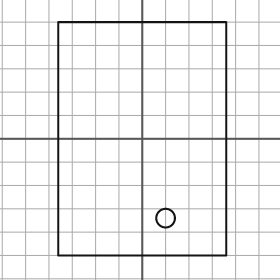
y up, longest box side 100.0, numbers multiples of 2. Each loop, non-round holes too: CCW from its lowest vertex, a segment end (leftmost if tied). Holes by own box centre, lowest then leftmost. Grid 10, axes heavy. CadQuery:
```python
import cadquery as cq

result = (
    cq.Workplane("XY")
    .moveTo(-36.0, -50.0)
    .lineTo(36.0, -50.0)
    .lineTo(36.0, 50.0)
    .lineTo(-36.0, 50.0)
    .close()
    .moveTo(10.0, -34.0)
    .circle(4.0)
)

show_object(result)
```